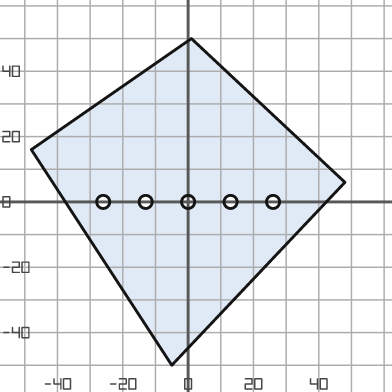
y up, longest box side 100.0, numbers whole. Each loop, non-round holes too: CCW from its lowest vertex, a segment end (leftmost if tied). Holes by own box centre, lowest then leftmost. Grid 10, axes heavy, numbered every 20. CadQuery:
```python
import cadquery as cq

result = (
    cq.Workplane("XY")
    .moveTo(-5.0, -50.0)
    .lineTo(48.0, 6.0)
    .lineTo(1.0, 50.0)
    .lineTo(-48.0, 16.0)
    .close()
    .moveTo(-26.0, 0.0)
    .circle(2.0)
    .moveTo(-13.0, 0.0)
    .circle(2.0)
    .moveTo(0.0, 0.0)
    .circle(2.0)
    .moveTo(13.0, 0.0)
    .circle(2.0)
    .moveTo(26.0, 0.0)
    .circle(2.0)
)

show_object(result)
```